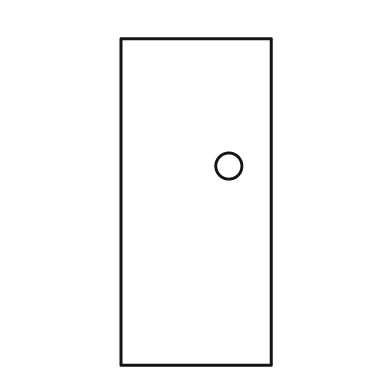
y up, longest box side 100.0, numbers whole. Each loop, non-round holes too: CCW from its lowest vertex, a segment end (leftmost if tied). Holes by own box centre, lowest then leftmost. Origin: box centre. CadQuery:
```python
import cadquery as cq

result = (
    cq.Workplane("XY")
    .moveTo(-23.0, -50.0)
    .lineTo(23.0, -50.0)
    .lineTo(23.0, 50.0)
    .lineTo(-23.0, 50.0)
    .close()
    .moveTo(10.0, 11.0)
    .circle(4.0)
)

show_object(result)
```